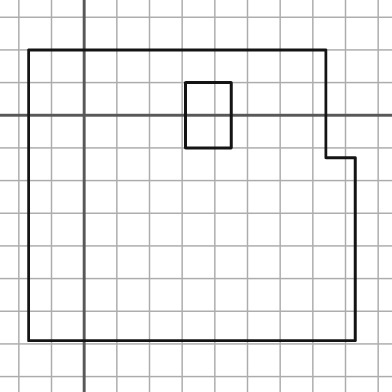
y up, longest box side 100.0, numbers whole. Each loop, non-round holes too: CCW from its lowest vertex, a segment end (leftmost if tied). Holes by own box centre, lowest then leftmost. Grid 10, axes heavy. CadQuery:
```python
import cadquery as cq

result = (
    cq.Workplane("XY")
    .moveTo(-17.0, -69.0)
    .lineTo(83.0, -69.0)
    .lineTo(83.0, -13.0)
    .lineTo(74.0, -13.0)
    .lineTo(74.0, 20.0)
    .lineTo(-17.0, 20.0)
    .close()
    .moveTo(31.0, -10.0)
    .lineTo(45.0, -10.0)
    .lineTo(45.0, 10.0)
    .lineTo(31.0, 10.0)
    .close()
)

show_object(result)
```